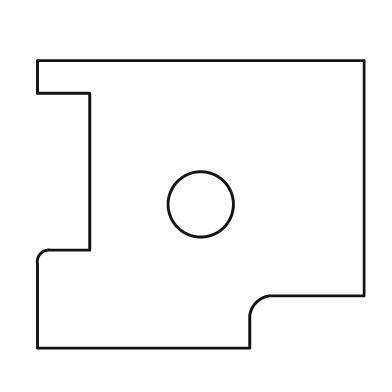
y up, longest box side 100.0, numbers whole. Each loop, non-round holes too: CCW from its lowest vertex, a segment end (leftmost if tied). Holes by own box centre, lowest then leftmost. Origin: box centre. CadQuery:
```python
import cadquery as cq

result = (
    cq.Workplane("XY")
    .moveTo(-50.0, -44.0)
    .lineTo(15.0, -44.0)
    .lineTo(15.0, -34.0)
    .threePointArc((17.0, -30.0), (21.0, -28.0))
    .lineTo(50.0, -28.0)
    .lineTo(50.0, 44.0)
    .lineTo(-50.0, 44.0)
    .lineTo(-50.0, 34.0)
    .lineTo(-34.0, 34.0)
    .lineTo(-34.0, -14.0)
    .lineTo(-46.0, -14.0)
    .threePointArc((-49.0, -15.0), (-50.0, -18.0))
    .close()
    .moveTo(0.0, 0.0)
    .circle(10.0)
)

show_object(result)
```